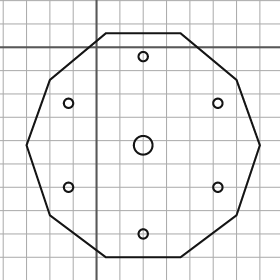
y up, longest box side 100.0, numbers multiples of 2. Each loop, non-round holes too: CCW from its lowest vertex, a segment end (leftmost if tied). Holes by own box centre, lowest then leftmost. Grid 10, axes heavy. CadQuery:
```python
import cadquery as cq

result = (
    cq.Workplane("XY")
    .moveTo(4.0, -90.0)
    .lineTo(36.0, -90.0)
    .lineTo(60.0, -72.0)
    .lineTo(70.0, -42.0)
    .lineTo(60.0, -14.0)
    .lineTo(36.0, 6.0)
    .lineTo(4.0, 6.0)
    .lineTo(-20.0, -14.0)
    .lineTo(-30.0, -42.0)
    .lineTo(-20.0, -72.0)
    .close()
    .moveTo(20.0, -80.0)
    .circle(2.0)
    .moveTo(-12.0, -60.0)
    .circle(2.0)
    .moveTo(52.0, -60.0)
    .circle(2.0)
    .moveTo(20.0, -42.0)
    .circle(4.0)
    .moveTo(-12.0, -24.0)
    .circle(2.0)
    .moveTo(52.0, -24.0)
    .circle(2.0)
    .moveTo(20.0, -4.0)
    .circle(2.0)
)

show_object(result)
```